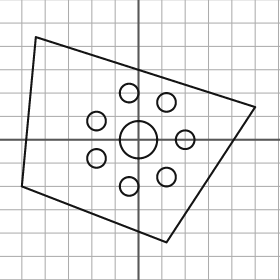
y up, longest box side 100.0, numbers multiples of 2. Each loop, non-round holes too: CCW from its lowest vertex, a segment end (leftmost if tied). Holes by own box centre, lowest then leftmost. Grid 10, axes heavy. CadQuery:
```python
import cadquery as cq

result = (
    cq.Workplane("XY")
    .moveTo(12.0, -44.0)
    .lineTo(50.0, 14.0)
    .lineTo(-44.0, 44.0)
    .lineTo(-50.0, -20.0)
    .close()
    .moveTo(-4.0, -20.0)
    .circle(4.0)
    .moveTo(12.0, -16.0)
    .circle(4.0)
    .moveTo(-18.0, -8.0)
    .circle(4.0)
    .moveTo(0.0, 0.0)
    .circle(8.0)
    .moveTo(20.0, 0.0)
    .circle(4.0)
    .moveTo(-18.0, 8.0)
    .circle(4.0)
    .moveTo(12.0, 16.0)
    .circle(4.0)
    .moveTo(-4.0, 20.0)
    .circle(4.0)
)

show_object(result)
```